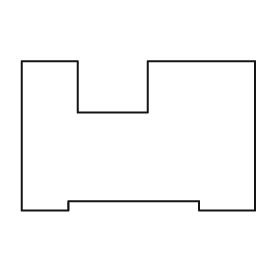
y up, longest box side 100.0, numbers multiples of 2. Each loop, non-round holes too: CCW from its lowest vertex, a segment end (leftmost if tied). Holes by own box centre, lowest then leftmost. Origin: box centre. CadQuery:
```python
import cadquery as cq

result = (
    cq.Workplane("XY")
    .moveTo(-50.0, -32.0)
    .lineTo(-30.0, -32.0)
    .lineTo(-30.0, -28.0)
    .lineTo(26.0, -28.0)
    .lineTo(26.0, -32.0)
    .lineTo(50.0, -32.0)
    .lineTo(50.0, 32.0)
    .lineTo(4.0, 32.0)
    .lineTo(4.0, 10.0)
    .lineTo(-26.0, 10.0)
    .lineTo(-26.0, 32.0)
    .lineTo(-50.0, 32.0)
    .close()
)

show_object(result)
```